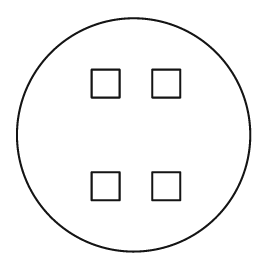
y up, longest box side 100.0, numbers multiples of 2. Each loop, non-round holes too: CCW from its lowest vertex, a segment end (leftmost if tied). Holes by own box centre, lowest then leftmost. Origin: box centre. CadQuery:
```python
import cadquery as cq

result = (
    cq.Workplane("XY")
    .moveTo(0.0, 0.0)
    .circle(50.0)
    .moveTo(-18.0, -28.0)
    .lineTo(-6.0, -28.0)
    .lineTo(-6.0, -16.0)
    .lineTo(-18.0, -16.0)
    .close()
    .moveTo(8.0, -28.0)
    .lineTo(20.0, -28.0)
    .lineTo(20.0, -16.0)
    .lineTo(8.0, -16.0)
    .close()
    .moveTo(-18.0, 16.0)
    .lineTo(-6.0, 16.0)
    .lineTo(-6.0, 28.0)
    .lineTo(-18.0, 28.0)
    .close()
    .moveTo(8.0, 16.0)
    .lineTo(20.0, 16.0)
    .lineTo(20.0, 28.0)
    .lineTo(8.0, 28.0)
    .close()
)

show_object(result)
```